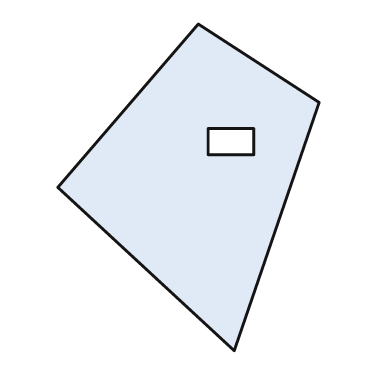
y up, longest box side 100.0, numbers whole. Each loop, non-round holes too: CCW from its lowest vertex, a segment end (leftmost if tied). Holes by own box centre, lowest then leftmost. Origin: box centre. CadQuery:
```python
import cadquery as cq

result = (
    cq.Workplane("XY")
    .moveTo(14.0, -50.0)
    .lineTo(40.0, 26.0)
    .lineTo(3.0, 50.0)
    .lineTo(-40.0, 0.0)
    .close()
    .moveTo(6.0, 10.0)
    .lineTo(20.0, 10.0)
    .lineTo(20.0, 18.0)
    .lineTo(6.0, 18.0)
    .close()
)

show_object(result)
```